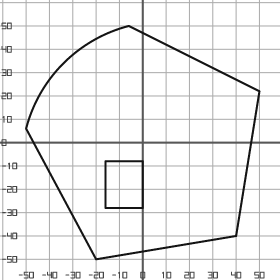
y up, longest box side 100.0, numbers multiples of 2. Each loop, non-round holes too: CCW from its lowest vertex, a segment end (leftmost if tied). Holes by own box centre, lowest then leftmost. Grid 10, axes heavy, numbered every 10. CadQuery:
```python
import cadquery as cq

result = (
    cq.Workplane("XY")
    .moveTo(-20.0, -50.0)
    .lineTo(40.0, -40.0)
    .lineTo(50.0, 22.0)
    .lineTo(-6.0, 50.0)
    .threePointArc((-34.0, 34.0), (-50.0, 6.0))
    .close()
    .moveTo(-16.0, -28.0)
    .lineTo(0.0, -28.0)
    .lineTo(0.0, -8.0)
    .lineTo(-16.0, -8.0)
    .close()
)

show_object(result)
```